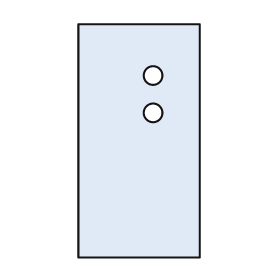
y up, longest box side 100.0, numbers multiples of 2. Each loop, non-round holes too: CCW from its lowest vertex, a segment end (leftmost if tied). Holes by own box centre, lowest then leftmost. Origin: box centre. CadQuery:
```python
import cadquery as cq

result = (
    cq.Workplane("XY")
    .moveTo(-26.0, -50.0)
    .lineTo(26.0, -50.0)
    .lineTo(26.0, 50.0)
    .lineTo(-26.0, 50.0)
    .close()
    .moveTo(6.0, 12.0)
    .circle(4.0)
    .moveTo(6.0, 28.0)
    .circle(4.0)
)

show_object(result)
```